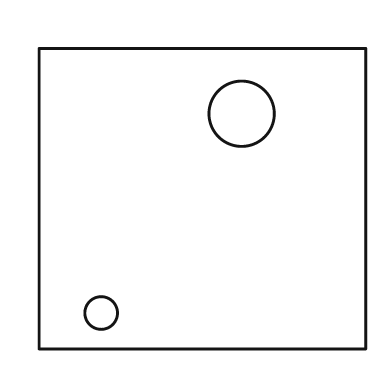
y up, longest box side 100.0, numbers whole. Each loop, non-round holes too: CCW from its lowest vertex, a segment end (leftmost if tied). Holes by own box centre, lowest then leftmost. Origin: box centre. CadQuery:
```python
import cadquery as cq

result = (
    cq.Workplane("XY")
    .moveTo(-50.0, -46.0)
    .lineTo(50.0, -46.0)
    .lineTo(50.0, 46.0)
    .lineTo(-50.0, 46.0)
    .close()
    .moveTo(-31.0, -35.0)
    .circle(5.0)
    .moveTo(12.0, 26.0)
    .circle(10.0)
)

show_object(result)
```